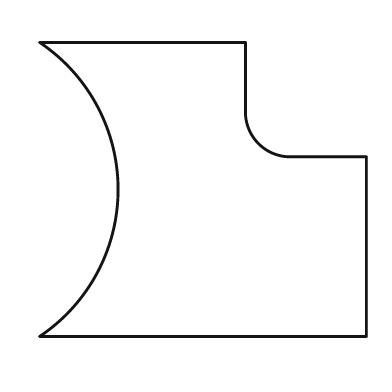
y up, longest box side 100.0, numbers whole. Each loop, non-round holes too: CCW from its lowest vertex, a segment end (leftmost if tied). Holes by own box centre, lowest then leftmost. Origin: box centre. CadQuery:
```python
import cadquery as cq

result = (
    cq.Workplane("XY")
    .moveTo(-50.0, -45.0)
    .lineTo(50.0, -45.0)
    .lineTo(50.0, 10.0)
    .lineTo(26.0, 10.0)
    .threePointArc((17.0, 14.0), (13.0, 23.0))
    .lineTo(13.0, 45.0)
    .lineTo(-50.0, 45.0)
    .threePointArc((-26.0, 0.0), (-50.0, -45.0))
    .close()
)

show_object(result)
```